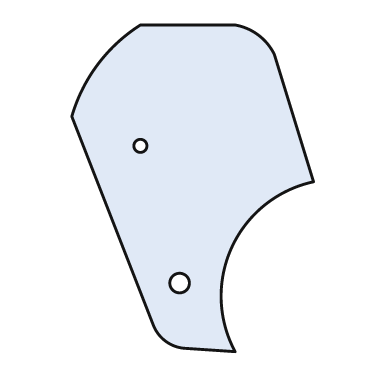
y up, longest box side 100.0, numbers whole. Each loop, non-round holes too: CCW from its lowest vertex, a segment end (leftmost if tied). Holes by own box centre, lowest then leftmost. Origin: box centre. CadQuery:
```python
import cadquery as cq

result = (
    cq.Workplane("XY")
    .moveTo(13.0, -50.0)
    .threePointArc((12.0, -18.0), (37.0, 2.0))
    .lineTo(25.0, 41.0)
    .threePointArc((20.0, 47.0), (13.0, 50.0))
    .lineTo(-16.0, 50.0)
    .threePointArc((-29.0, 38.0), (-37.0, 22.0))
    .lineTo(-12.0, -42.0)
    .threePointArc((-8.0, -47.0), (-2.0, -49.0))
    .close()
    .moveTo(-4.0, -29.0)
    .circle(3.0)
    .moveTo(-16.0, 13.0)
    .circle(2.0)
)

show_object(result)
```